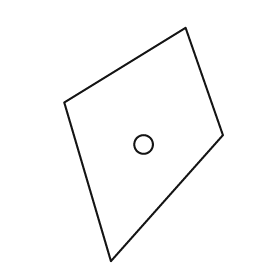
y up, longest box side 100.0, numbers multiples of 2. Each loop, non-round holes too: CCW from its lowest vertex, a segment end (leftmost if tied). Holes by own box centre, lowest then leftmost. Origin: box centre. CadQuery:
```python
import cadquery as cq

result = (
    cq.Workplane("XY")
    .moveTo(-14.0, -50.0)
    .lineTo(34.0, 4.0)
    .lineTo(18.0, 50.0)
    .lineTo(-34.0, 18.0)
    .close()
    .moveTo(0.0, 0.0)
    .circle(4.0)
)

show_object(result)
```